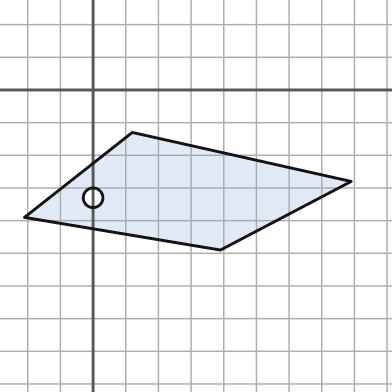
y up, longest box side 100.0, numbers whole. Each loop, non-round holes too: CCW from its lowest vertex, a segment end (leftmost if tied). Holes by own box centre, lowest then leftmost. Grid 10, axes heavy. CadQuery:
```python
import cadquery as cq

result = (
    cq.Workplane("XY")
    .moveTo(39.0, -49.0)
    .lineTo(79.0, -28.0)
    .lineTo(12.0, -13.0)
    .lineTo(-21.0, -39.0)
    .close()
    .moveTo(0.0, -33.0)
    .circle(3.0)
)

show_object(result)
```